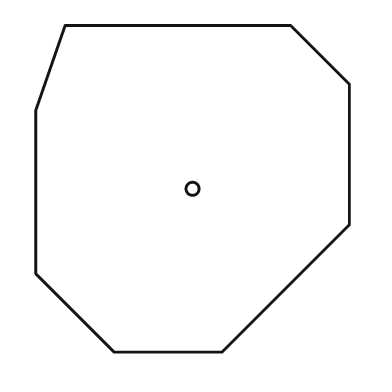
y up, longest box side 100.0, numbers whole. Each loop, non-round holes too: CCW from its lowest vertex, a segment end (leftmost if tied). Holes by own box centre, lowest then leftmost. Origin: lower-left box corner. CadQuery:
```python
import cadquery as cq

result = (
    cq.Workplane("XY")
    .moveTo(24.0, 0.0)
    .lineTo(57.0, 0.0)
    .lineTo(96.0, 39.0)
    .lineTo(96.0, 82.0)
    .lineTo(78.0, 100.0)
    .lineTo(9.0, 100.0)
    .lineTo(0.0, 74.0)
    .lineTo(0.0, 24.0)
    .close()
    .moveTo(48.0, 50.0)
    .circle(2.0)
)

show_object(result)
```